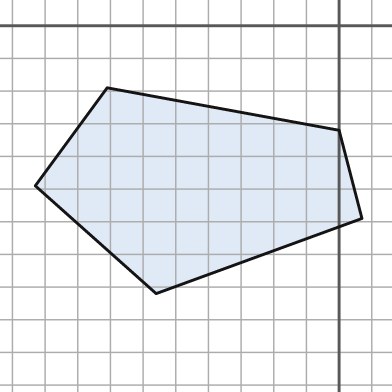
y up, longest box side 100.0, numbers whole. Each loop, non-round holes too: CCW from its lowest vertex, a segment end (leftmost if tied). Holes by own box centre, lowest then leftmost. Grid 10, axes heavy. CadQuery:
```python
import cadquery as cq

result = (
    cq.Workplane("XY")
    .moveTo(-56.0, -82.0)
    .lineTo(7.0, -59.0)
    .lineTo(0.0, -32.0)
    .lineTo(-71.0, -19.0)
    .lineTo(-93.0, -49.0)
    .close()
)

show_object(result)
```